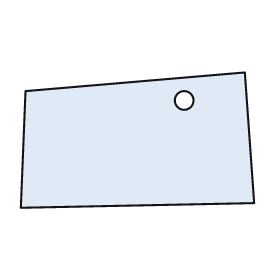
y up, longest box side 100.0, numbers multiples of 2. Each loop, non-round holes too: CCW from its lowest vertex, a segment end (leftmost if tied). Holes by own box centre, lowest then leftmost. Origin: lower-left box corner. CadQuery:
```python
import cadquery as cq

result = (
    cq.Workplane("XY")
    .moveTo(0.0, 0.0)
    .lineTo(100.0, 2.0)
    .lineTo(96.0, 58.0)
    .lineTo(2.0, 50.0)
    .close()
    .moveTo(70.0, 46.0)
    .circle(4.0)
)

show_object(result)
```